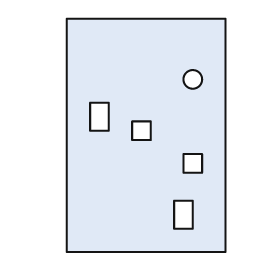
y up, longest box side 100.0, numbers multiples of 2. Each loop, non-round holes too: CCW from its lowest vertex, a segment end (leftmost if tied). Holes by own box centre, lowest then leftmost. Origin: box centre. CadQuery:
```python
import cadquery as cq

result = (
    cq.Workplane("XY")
    .moveTo(-34.0, -50.0)
    .lineTo(34.0, -50.0)
    .lineTo(34.0, 50.0)
    .lineTo(-34.0, 50.0)
    .close()
    .moveTo(12.0, -40.0)
    .lineTo(20.0, -40.0)
    .lineTo(20.0, -28.0)
    .lineTo(12.0, -28.0)
    .close()
    .moveTo(16.0, -16.0)
    .lineTo(24.0, -16.0)
    .lineTo(24.0, -8.0)
    .lineTo(16.0, -8.0)
    .close()
    .moveTo(-6.0, -2.0)
    .lineTo(2.0, -2.0)
    .lineTo(2.0, 6.0)
    .lineTo(-6.0, 6.0)
    .close()
    .moveTo(-24.0, 2.0)
    .lineTo(-16.0, 2.0)
    .lineTo(-16.0, 14.0)
    .lineTo(-24.0, 14.0)
    .close()
    .moveTo(20.0, 24.0)
    .circle(4.0)
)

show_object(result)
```